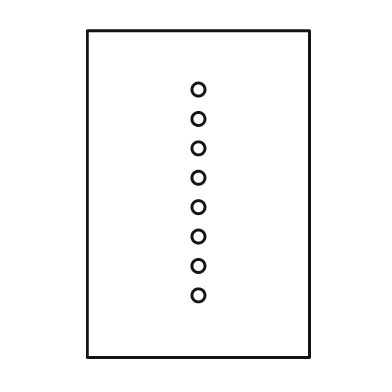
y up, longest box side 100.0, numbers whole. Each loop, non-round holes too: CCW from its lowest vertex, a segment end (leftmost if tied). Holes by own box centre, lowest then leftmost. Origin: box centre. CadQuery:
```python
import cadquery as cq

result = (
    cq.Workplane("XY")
    .moveTo(-34.0, -50.0)
    .lineTo(34.0, -50.0)
    .lineTo(34.0, 50.0)
    .lineTo(-34.0, 50.0)
    .close()
    .moveTo(0.0, -31.0)
    .circle(2.0)
    .moveTo(0.0, -22.0)
    .circle(2.0)
    .moveTo(0.0, -13.0)
    .circle(2.0)
    .moveTo(0.0, -4.0)
    .circle(2.0)
    .moveTo(0.0, 5.0)
    .circle(2.0)
    .moveTo(0.0, 14.0)
    .circle(2.0)
    .moveTo(0.0, 23.0)
    .circle(2.0)
    .moveTo(0.0, 32.0)
    .circle(2.0)
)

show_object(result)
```